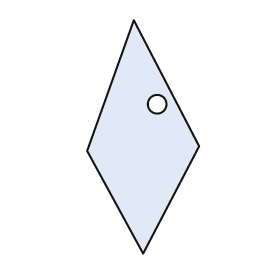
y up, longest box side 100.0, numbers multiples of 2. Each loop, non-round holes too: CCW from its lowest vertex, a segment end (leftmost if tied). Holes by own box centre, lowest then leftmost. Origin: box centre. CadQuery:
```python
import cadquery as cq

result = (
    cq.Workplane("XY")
    .moveTo(0.0, -50.0)
    .lineTo(24.0, -4.0)
    .lineTo(-4.0, 50.0)
    .lineTo(-24.0, -6.0)
    .close()
    .moveTo(6.0, 14.0)
    .circle(4.0)
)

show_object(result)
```